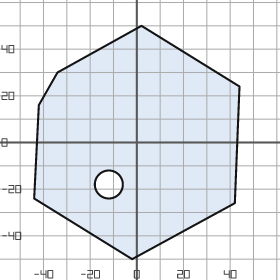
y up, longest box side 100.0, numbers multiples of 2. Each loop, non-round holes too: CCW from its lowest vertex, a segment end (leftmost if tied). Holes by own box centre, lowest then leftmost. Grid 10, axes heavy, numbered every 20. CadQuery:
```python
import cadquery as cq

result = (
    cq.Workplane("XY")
    .moveTo(-2.0, -50.0)
    .lineTo(42.0, -26.0)
    .lineTo(44.0, 24.0)
    .lineTo(2.0, 50.0)
    .lineTo(-34.0, 30.0)
    .lineTo(-42.0, 16.0)
    .lineTo(-44.0, -24.0)
    .close()
    .moveTo(-12.0, -18.0)
    .circle(6.0)
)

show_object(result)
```